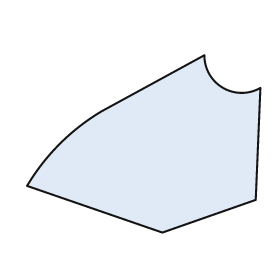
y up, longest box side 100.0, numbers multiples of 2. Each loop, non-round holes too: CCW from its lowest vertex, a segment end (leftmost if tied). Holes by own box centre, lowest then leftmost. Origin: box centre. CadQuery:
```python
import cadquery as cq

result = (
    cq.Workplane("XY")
    .moveTo(8.0, -38.0)
    .lineTo(48.0, -24.0)
    .lineTo(50.0, 24.0)
    .threePointArc((34.0, 24.0), (26.0, 38.0))
    .lineTo(-18.0, 14.0)
    .threePointArc((-36.0, 0.0), (-50.0, -18.0))
    .close()
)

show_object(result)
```